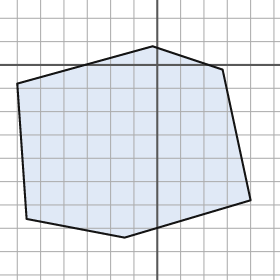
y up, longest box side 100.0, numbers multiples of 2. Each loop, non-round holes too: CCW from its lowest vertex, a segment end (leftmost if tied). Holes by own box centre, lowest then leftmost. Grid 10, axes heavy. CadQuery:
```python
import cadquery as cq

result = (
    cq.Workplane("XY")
    .moveTo(-14.0, -74.0)
    .lineTo(40.0, -58.0)
    .lineTo(28.0, -2.0)
    .lineTo(-2.0, 8.0)
    .lineTo(-60.0, -8.0)
    .lineTo(-56.0, -66.0)
    .close()
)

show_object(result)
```